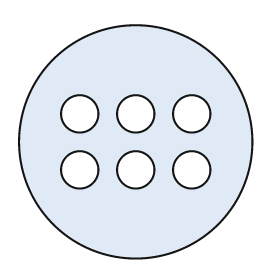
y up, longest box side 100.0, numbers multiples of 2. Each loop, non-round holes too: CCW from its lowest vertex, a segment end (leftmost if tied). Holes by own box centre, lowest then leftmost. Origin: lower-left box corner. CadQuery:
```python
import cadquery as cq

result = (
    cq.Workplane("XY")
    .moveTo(50.0, 50.0)
    .circle(50.0)
    .moveTo(26.0, 38.0)
    .circle(8.0)
    .moveTo(50.0, 38.0)
    .circle(8.0)
    .moveTo(74.0, 38.0)
    .circle(8.0)
    .moveTo(26.0, 62.0)
    .circle(8.0)
    .moveTo(50.0, 62.0)
    .circle(8.0)
    .moveTo(74.0, 62.0)
    .circle(8.0)
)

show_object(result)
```